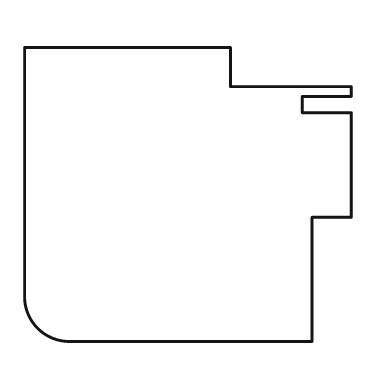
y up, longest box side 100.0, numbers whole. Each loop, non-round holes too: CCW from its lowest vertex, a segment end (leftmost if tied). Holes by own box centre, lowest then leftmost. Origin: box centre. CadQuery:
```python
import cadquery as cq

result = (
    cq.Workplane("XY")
    .moveTo(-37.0, -45.0)
    .lineTo(38.0, -45.0)
    .lineTo(38.0, -7.0)
    .lineTo(50.0, -7.0)
    .lineTo(50.0, 25.0)
    .lineTo(35.0, 25.0)
    .lineTo(35.0, 30.0)
    .lineTo(50.0, 30.0)
    .lineTo(50.0, 33.0)
    .lineTo(13.0, 33.0)
    .lineTo(13.0, 45.0)
    .lineTo(-50.0, 45.0)
    .lineTo(-50.0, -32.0)
    .threePointArc((-46.0, -41.0), (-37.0, -45.0))
    .close()
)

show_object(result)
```